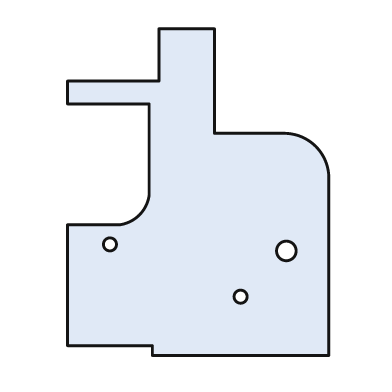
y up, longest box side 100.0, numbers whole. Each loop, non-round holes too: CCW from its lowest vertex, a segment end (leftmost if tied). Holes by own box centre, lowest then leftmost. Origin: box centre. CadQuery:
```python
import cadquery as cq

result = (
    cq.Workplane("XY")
    .moveTo(-14.0, -50.0)
    .lineTo(40.0, -50.0)
    .lineTo(40.0, 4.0)
    .threePointArc((36.0, 14.0), (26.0, 18.0))
    .lineTo(5.0, 18.0)
    .lineTo(5.0, 50.0)
    .lineTo(-12.0, 50.0)
    .lineTo(-12.0, 34.0)
    .lineTo(-40.0, 34.0)
    .lineTo(-40.0, 27.0)
    .lineTo(-15.0, 27.0)
    .lineTo(-15.0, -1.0)
    .threePointArc((-18.0, -7.0), (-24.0, -10.0))
    .lineTo(-40.0, -10.0)
    .lineTo(-40.0, -47.0)
    .lineTo(-14.0, -47.0)
    .close()
    .moveTo(13.0, -32.0)
    .circle(2.0)
    .moveTo(27.0, -18.0)
    .circle(3.0)
    .moveTo(-27.0, -16.0)
    .circle(2.0)
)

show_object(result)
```